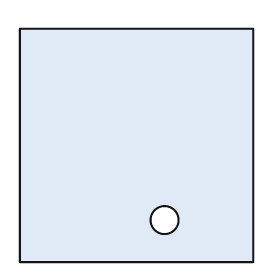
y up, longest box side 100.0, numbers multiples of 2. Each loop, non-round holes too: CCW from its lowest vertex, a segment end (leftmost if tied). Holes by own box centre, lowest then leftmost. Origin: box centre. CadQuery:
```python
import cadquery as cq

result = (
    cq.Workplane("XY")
    .moveTo(-50.0, -50.0)
    .lineTo(50.0, -50.0)
    .lineTo(50.0, 50.0)
    .lineTo(-50.0, 50.0)
    .close()
    .moveTo(12.0, -32.0)
    .circle(6.0)
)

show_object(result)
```